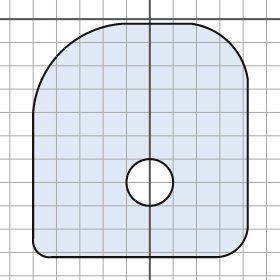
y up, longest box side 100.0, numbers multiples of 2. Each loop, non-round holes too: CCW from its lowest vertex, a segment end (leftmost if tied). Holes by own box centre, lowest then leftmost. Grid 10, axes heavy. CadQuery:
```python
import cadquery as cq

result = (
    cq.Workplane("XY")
    .moveTo(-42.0, -102.0)
    .lineTo(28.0, -102.0)
    .threePointArc((38.0, -98.0), (42.0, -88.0))
    .lineTo(42.0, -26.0)
    .threePointArc((34.0, -10.0), (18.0, -2.0))
    .lineTo(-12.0, -2.0)
    .threePointArc((-38.0, -14.0), (-50.0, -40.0))
    .lineTo(-50.0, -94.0)
    .threePointArc((-48.0, -100.0), (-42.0, -102.0))
    .close()
    .moveTo(0.0, -70.0)
    .circle(10.0)
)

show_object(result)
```